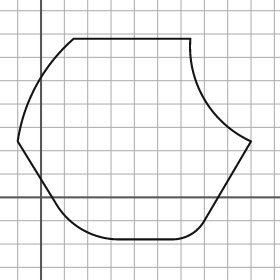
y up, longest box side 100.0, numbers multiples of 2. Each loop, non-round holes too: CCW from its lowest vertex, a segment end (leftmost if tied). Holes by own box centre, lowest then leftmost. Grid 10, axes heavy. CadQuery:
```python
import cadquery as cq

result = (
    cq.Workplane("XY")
    .moveTo(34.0, -18.0)
    .lineTo(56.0, -18.0)
    .threePointArc((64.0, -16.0), (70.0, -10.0))
    .lineTo(90.0, 24.0)
    .threePointArc((70.0, 42.0), (64.0, 68.0))
    .lineTo(14.0, 68.0)
    .threePointArc((-2.0, 48.0), (-10.0, 24.0))
    .lineTo(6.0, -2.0)
    .threePointArc((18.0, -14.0), (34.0, -18.0))
    .close()
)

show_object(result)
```